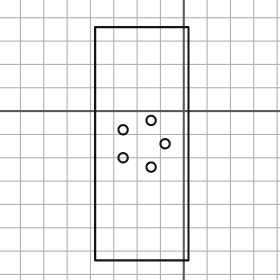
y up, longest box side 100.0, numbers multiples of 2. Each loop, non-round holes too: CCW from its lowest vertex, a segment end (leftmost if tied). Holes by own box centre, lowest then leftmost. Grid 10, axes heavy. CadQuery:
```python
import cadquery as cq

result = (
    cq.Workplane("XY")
    .moveTo(-38.0, -64.0)
    .lineTo(2.0, -64.0)
    .lineTo(2.0, 36.0)
    .lineTo(-38.0, 36.0)
    .close()
    .moveTo(-14.0, -24.0)
    .circle(2.0)
    .moveTo(-26.0, -20.0)
    .circle(2.0)
    .moveTo(-8.0, -14.0)
    .circle(2.0)
    .moveTo(-26.0, -8.0)
    .circle(2.0)
    .moveTo(-14.0, -4.0)
    .circle(2.0)
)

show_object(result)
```